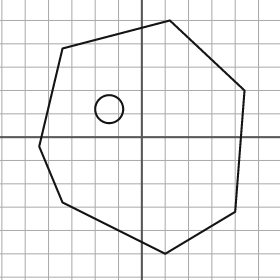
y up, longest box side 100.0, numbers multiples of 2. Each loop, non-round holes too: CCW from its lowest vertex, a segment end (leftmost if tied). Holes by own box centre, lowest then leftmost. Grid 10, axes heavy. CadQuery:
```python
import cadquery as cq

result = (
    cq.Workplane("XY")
    .moveTo(10.0, -50.0)
    .lineTo(40.0, -32.0)
    .lineTo(44.0, 20.0)
    .lineTo(12.0, 50.0)
    .lineTo(-34.0, 38.0)
    .lineTo(-44.0, -4.0)
    .lineTo(-34.0, -28.0)
    .close()
    .moveTo(-14.0, 12.0)
    .circle(6.0)
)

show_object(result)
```